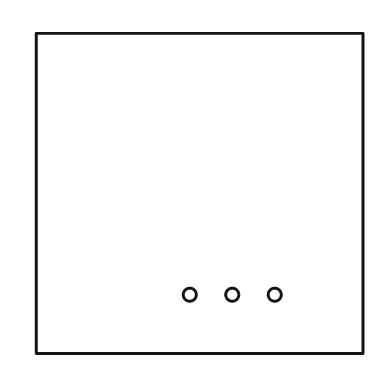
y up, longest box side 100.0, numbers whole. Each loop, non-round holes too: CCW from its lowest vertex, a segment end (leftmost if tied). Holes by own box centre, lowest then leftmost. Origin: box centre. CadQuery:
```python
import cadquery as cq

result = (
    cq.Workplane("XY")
    .moveTo(-50.0, -49.0)
    .lineTo(50.0, -49.0)
    .lineTo(50.0, 49.0)
    .lineTo(-50.0, 49.0)
    .close()
    .moveTo(-3.0, -31.0)
    .circle(2.0)
    .moveTo(10.0, -31.0)
    .circle(2.0)
    .moveTo(23.0, -31.0)
    .circle(2.0)
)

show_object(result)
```